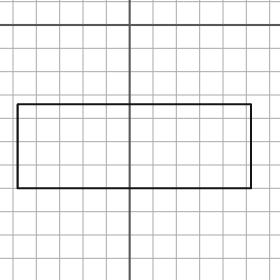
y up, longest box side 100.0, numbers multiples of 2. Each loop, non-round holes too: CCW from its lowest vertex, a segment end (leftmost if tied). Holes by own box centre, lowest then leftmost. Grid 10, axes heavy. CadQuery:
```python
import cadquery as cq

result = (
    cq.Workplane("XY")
    .moveTo(-48.0, -70.0)
    .lineTo(52.0, -70.0)
    .lineTo(52.0, -34.0)
    .lineTo(-48.0, -34.0)
    .close()
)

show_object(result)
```